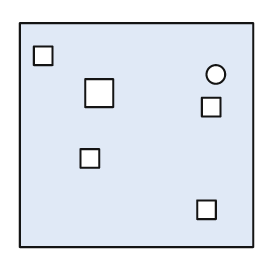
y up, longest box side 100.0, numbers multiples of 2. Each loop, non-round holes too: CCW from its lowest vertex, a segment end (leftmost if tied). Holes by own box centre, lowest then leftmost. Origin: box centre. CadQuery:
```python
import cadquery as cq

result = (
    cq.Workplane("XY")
    .moveTo(-50.0, -48.0)
    .lineTo(50.0, -48.0)
    .lineTo(50.0, 48.0)
    .lineTo(-50.0, 48.0)
    .close()
    .moveTo(26.0, -36.0)
    .lineTo(34.0, -36.0)
    .lineTo(34.0, -28.0)
    .lineTo(26.0, -28.0)
    .close()
    .moveTo(-24.0, -14.0)
    .lineTo(-16.0, -14.0)
    .lineTo(-16.0, -6.0)
    .lineTo(-24.0, -6.0)
    .close()
    .moveTo(28.0, 8.0)
    .lineTo(36.0, 8.0)
    .lineTo(36.0, 16.0)
    .lineTo(28.0, 16.0)
    .close()
    .moveTo(-22.0, 12.0)
    .lineTo(-10.0, 12.0)
    .lineTo(-10.0, 24.0)
    .lineTo(-22.0, 24.0)
    .close()
    .moveTo(34.0, 26.0)
    .circle(4.0)
    .moveTo(-44.0, 30.0)
    .lineTo(-36.0, 30.0)
    .lineTo(-36.0, 38.0)
    .lineTo(-44.0, 38.0)
    .close()
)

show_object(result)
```